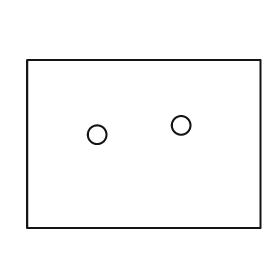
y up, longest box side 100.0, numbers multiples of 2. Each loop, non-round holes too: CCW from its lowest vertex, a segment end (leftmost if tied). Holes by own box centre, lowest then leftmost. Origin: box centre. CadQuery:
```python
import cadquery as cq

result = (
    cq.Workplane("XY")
    .moveTo(-50.0, -36.0)
    .lineTo(50.0, -36.0)
    .lineTo(50.0, 36.0)
    .lineTo(-50.0, 36.0)
    .close()
    .moveTo(-20.0, 4.0)
    .circle(4.0)
    .moveTo(16.0, 8.0)
    .circle(4.0)
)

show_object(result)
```